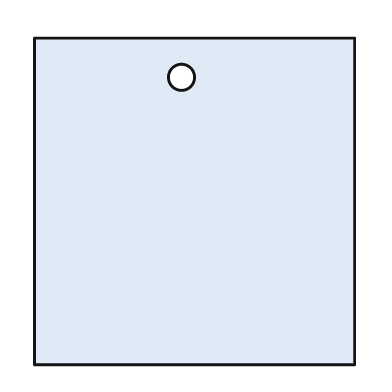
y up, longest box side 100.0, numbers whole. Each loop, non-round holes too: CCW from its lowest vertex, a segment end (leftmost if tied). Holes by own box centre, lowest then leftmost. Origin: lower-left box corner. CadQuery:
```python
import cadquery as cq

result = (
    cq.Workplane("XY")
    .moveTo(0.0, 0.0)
    .lineTo(98.0, 0.0)
    .lineTo(98.0, 100.0)
    .lineTo(0.0, 100.0)
    .close()
    .moveTo(45.0, 88.0)
    .circle(4.0)
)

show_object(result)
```